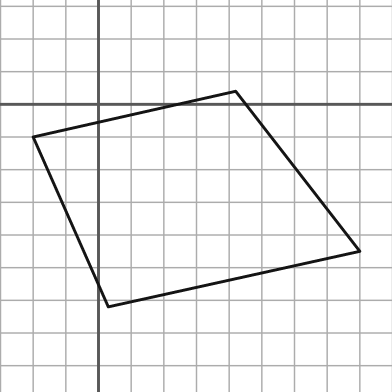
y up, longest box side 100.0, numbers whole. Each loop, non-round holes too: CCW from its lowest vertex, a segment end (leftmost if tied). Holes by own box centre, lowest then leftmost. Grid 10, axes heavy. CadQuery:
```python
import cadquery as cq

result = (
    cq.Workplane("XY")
    .moveTo(3.0, -62.0)
    .lineTo(80.0, -45.0)
    .lineTo(42.0, 4.0)
    .lineTo(-20.0, -10.0)
    .close()
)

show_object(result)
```